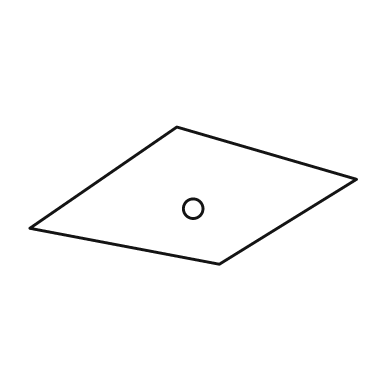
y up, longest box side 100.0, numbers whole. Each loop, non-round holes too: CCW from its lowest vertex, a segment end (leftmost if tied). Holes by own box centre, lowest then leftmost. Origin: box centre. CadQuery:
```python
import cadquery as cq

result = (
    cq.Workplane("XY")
    .moveTo(8.0, -21.0)
    .lineTo(50.0, 5.0)
    .lineTo(-5.0, 21.0)
    .lineTo(-50.0, -10.0)
    .close()
    .moveTo(0.0, -4.0)
    .circle(3.0)
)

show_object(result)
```